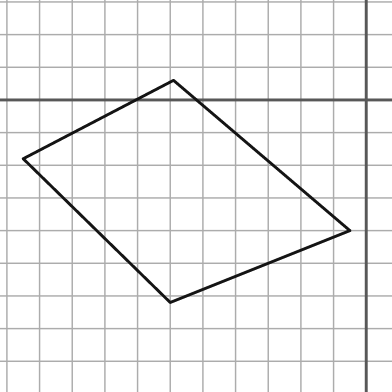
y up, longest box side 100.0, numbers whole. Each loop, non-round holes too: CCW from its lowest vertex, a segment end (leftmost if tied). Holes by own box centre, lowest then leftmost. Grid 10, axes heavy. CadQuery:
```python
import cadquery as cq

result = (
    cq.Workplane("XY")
    .moveTo(-60.0, -62.0)
    .lineTo(-5.0, -40.0)
    .lineTo(-59.0, 6.0)
    .lineTo(-105.0, -18.0)
    .close()
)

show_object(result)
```